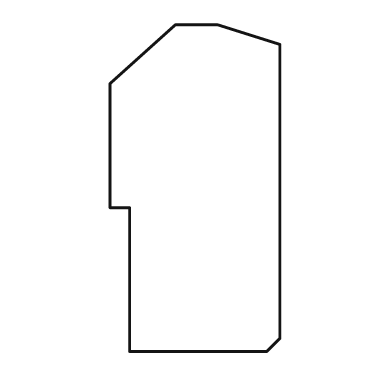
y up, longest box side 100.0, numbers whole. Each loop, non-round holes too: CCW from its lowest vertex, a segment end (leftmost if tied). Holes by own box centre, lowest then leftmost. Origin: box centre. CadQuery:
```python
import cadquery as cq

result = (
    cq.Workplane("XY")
    .moveTo(-20.0, -50.0)
    .lineTo(22.0, -50.0)
    .lineTo(26.0, -46.0)
    .lineTo(26.0, 44.0)
    .lineTo(7.0, 50.0)
    .lineTo(-6.0, 50.0)
    .lineTo(-26.0, 32.0)
    .lineTo(-26.0, -6.0)
    .lineTo(-20.0, -6.0)
    .close()
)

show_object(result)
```